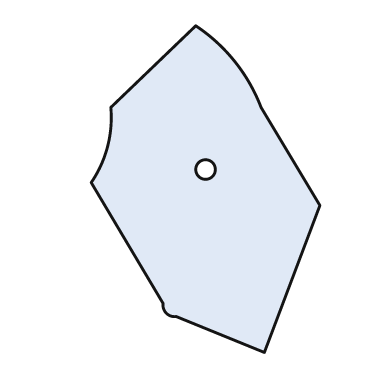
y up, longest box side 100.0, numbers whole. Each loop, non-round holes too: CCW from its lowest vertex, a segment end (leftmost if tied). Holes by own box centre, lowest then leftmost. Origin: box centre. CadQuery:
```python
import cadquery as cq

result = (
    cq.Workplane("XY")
    .moveTo(18.0, -50.0)
    .lineTo(35.0, -5.0)
    .lineTo(17.0, 25.0)
    .threePointArc((9.0, 39.0), (-3.0, 50.0))
    .lineTo(-29.0, 25.0)
    .threePointArc((-30.0, 13.0), (-35.0, 2.0))
    .lineTo(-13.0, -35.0)
    .threePointArc((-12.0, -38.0), (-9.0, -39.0))
    .close()
    .moveTo(0.0, 6.0)
    .circle(3.0)
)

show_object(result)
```